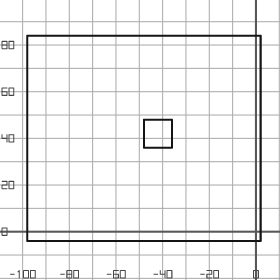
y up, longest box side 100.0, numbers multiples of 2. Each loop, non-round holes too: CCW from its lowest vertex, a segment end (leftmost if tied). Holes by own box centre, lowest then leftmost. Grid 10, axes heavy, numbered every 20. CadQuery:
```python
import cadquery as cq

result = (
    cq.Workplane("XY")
    .moveTo(-98.0, -4.0)
    .lineTo(2.0, -4.0)
    .lineTo(2.0, 84.0)
    .lineTo(-98.0, 84.0)
    .close()
    .moveTo(-48.0, 36.0)
    .lineTo(-36.0, 36.0)
    .lineTo(-36.0, 48.0)
    .lineTo(-48.0, 48.0)
    .close()
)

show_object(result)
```